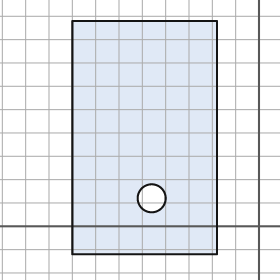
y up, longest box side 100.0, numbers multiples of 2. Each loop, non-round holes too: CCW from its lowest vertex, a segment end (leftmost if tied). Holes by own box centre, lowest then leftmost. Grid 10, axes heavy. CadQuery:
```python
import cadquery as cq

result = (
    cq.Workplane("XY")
    .moveTo(-80.0, -12.0)
    .lineTo(-18.0, -12.0)
    .lineTo(-18.0, 88.0)
    .lineTo(-80.0, 88.0)
    .close()
    .moveTo(-46.0, 12.0)
    .circle(6.0)
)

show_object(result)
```